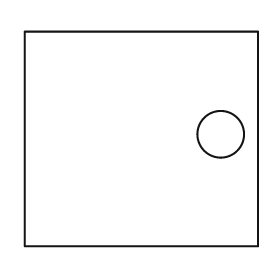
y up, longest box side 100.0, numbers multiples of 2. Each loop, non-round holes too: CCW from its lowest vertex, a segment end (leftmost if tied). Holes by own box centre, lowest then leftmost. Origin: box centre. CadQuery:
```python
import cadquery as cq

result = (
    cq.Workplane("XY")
    .moveTo(-50.0, -46.0)
    .lineTo(50.0, -46.0)
    .lineTo(50.0, 46.0)
    .lineTo(-50.0, 46.0)
    .close()
    .moveTo(34.0, 2.0)
    .circle(10.0)
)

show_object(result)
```